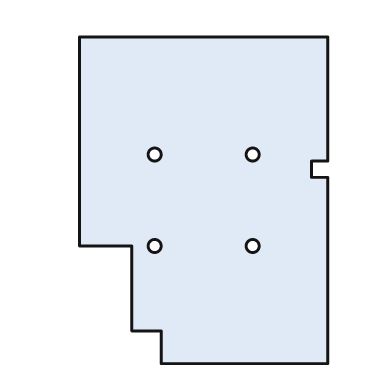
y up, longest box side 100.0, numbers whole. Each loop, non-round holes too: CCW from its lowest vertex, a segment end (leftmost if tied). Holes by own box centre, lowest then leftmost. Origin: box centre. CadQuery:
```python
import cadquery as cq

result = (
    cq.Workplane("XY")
    .moveTo(-13.0, -50.0)
    .lineTo(38.0, -50.0)
    .lineTo(38.0, 7.0)
    .lineTo(33.0, 7.0)
    .lineTo(33.0, 12.0)
    .lineTo(38.0, 12.0)
    .lineTo(38.0, 50.0)
    .lineTo(-38.0, 50.0)
    .lineTo(-38.0, -14.0)
    .lineTo(-22.0, -14.0)
    .lineTo(-22.0, -40.0)
    .lineTo(-13.0, -40.0)
    .close()
    .moveTo(-15.0, -14.0)
    .circle(2.0)
    .moveTo(15.0, -14.0)
    .circle(2.0)
    .moveTo(-15.0, 14.0)
    .circle(2.0)
    .moveTo(15.0, 14.0)
    .circle(2.0)
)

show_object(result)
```